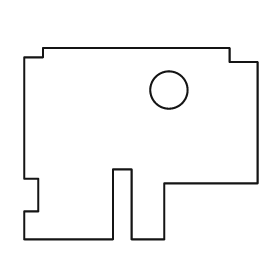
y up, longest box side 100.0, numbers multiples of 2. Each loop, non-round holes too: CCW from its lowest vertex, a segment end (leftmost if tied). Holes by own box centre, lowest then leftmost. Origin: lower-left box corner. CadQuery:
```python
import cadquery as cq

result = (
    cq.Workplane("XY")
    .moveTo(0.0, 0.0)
    .lineTo(38.0, 0.0)
    .lineTo(38.0, 30.0)
    .lineTo(46.0, 30.0)
    .lineTo(46.0, 0.0)
    .lineTo(60.0, 0.0)
    .lineTo(60.0, 24.0)
    .lineTo(100.0, 24.0)
    .lineTo(100.0, 76.0)
    .lineTo(88.0, 76.0)
    .lineTo(88.0, 82.0)
    .lineTo(8.0, 82.0)
    .lineTo(8.0, 78.0)
    .lineTo(0.0, 78.0)
    .lineTo(0.0, 26.0)
    .lineTo(6.0, 26.0)
    .lineTo(6.0, 12.0)
    .lineTo(0.0, 12.0)
    .close()
    .moveTo(62.0, 64.0)
    .circle(8.0)
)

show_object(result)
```